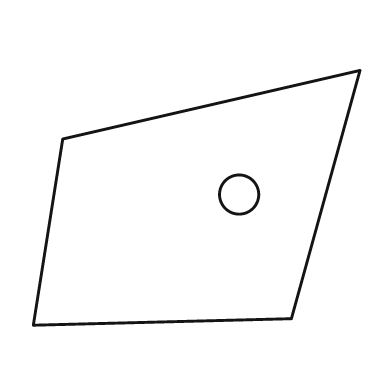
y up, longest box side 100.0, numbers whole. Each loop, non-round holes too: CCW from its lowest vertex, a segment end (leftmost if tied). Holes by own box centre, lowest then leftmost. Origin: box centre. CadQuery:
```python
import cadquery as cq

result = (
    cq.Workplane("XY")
    .moveTo(-50.0, -39.0)
    .lineTo(29.0, -37.0)
    .lineTo(50.0, 39.0)
    .lineTo(-41.0, 18.0)
    .close()
    .moveTo(13.0, 1.0)
    .circle(6.0)
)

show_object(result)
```